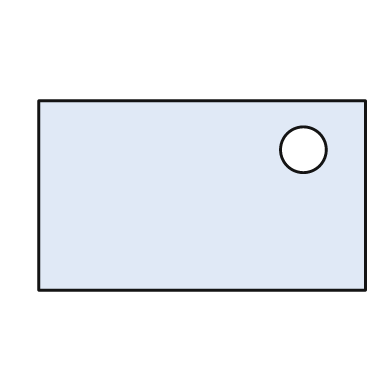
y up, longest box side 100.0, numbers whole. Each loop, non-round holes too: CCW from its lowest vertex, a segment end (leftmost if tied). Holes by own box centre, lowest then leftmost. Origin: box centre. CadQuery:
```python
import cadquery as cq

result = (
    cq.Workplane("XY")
    .moveTo(-50.0, -29.0)
    .lineTo(50.0, -29.0)
    .lineTo(50.0, 29.0)
    .lineTo(-50.0, 29.0)
    .close()
    .moveTo(31.0, 14.0)
    .circle(7.0)
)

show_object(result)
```